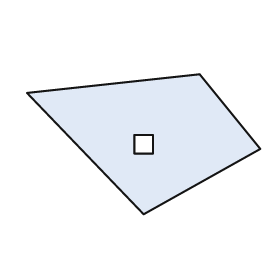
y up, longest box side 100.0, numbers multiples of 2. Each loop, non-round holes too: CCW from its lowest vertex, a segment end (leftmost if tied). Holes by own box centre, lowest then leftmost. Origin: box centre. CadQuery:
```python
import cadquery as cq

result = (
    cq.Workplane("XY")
    .moveTo(0.0, -30.0)
    .lineTo(50.0, -2.0)
    .lineTo(24.0, 30.0)
    .lineTo(-50.0, 22.0)
    .close()
    .moveTo(-4.0, -4.0)
    .lineTo(4.0, -4.0)
    .lineTo(4.0, 4.0)
    .lineTo(-4.0, 4.0)
    .close()
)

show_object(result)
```